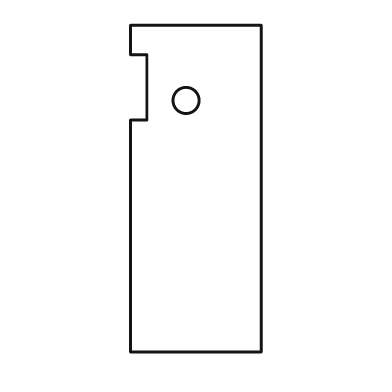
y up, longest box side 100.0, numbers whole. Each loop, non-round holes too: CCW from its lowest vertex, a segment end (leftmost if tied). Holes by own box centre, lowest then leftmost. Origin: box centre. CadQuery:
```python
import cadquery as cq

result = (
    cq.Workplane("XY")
    .moveTo(-20.0, -50.0)
    .lineTo(20.0, -50.0)
    .lineTo(20.0, 50.0)
    .lineTo(-20.0, 50.0)
    .lineTo(-20.0, 41.0)
    .lineTo(-15.0, 41.0)
    .lineTo(-15.0, 21.0)
    .lineTo(-20.0, 21.0)
    .close()
    .moveTo(-3.0, 27.0)
    .circle(4.0)
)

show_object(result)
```